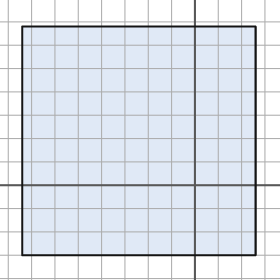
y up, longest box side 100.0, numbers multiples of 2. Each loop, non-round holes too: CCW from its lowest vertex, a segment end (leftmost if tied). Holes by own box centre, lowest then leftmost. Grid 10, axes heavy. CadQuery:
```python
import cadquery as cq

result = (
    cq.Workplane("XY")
    .moveTo(-74.0, -30.0)
    .lineTo(26.0, -30.0)
    .lineTo(26.0, 68.0)
    .lineTo(-74.0, 68.0)
    .close()
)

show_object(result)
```